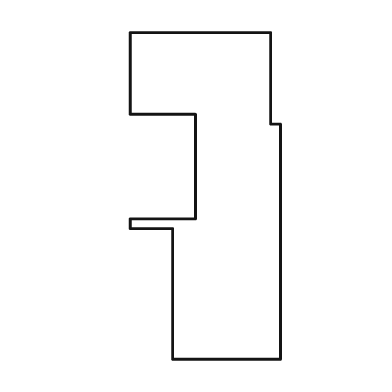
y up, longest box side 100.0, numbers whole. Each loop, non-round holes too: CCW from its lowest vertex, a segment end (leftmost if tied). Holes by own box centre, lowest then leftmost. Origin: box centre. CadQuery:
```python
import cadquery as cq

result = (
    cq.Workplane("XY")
    .moveTo(-10.0, -50.0)
    .lineTo(23.0, -50.0)
    .lineTo(23.0, 22.0)
    .lineTo(20.0, 22.0)
    .lineTo(20.0, 50.0)
    .lineTo(-23.0, 50.0)
    .lineTo(-23.0, 25.0)
    .lineTo(-3.0, 25.0)
    .lineTo(-3.0, -7.0)
    .lineTo(-23.0, -7.0)
    .lineTo(-23.0, -10.0)
    .lineTo(-10.0, -10.0)
    .close()
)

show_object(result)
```